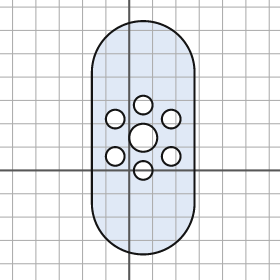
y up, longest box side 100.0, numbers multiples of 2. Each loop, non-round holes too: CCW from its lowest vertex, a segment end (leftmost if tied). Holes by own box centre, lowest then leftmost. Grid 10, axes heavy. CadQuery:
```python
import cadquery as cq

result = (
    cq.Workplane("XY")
    .moveTo(-16.0, -14.0)
    .threePointArc((6.0, -36.0), (28.0, -14.0))
    .lineTo(28.0, 42.0)
    .threePointArc((6.0, 64.0), (-16.0, 42.0))
    .close()
    .moveTo(6.0, 0.0)
    .circle(4.0)
    .moveTo(-6.0, 6.0)
    .circle(4.0)
    .moveTo(18.0, 6.0)
    .circle(4.0)
    .moveTo(6.0, 14.0)
    .circle(6.0)
    .moveTo(-6.0, 22.0)
    .circle(4.0)
    .moveTo(18.0, 22.0)
    .circle(4.0)
    .moveTo(6.0, 28.0)
    .circle(4.0)
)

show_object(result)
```